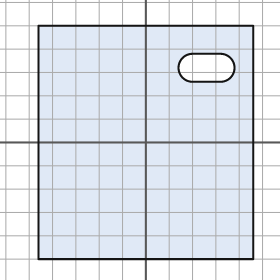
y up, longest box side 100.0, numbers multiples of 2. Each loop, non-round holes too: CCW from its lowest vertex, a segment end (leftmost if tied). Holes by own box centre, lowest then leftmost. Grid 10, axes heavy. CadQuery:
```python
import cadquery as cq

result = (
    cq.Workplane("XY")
    .moveTo(-46.0, -50.0)
    .lineTo(46.0, -50.0)
    .lineTo(46.0, 50.0)
    .lineTo(-46.0, 50.0)
    .close()
    .moveTo(20.0, 26.0)
    .lineTo(32.0, 26.0)
    .threePointArc((38.0, 32.0), (32.0, 38.0))
    .lineTo(20.0, 38.0)
    .threePointArc((14.0, 32.0), (20.0, 26.0))
    .close()
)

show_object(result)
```